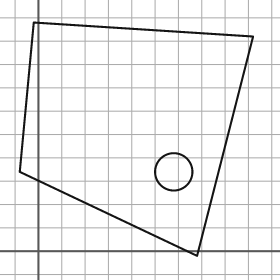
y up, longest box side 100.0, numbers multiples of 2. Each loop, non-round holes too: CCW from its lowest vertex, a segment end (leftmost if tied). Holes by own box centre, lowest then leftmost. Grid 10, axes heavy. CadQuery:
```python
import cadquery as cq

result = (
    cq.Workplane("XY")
    .moveTo(68.0, -2.0)
    .lineTo(92.0, 92.0)
    .lineTo(-2.0, 98.0)
    .lineTo(-8.0, 34.0)
    .close()
    .moveTo(58.0, 34.0)
    .circle(8.0)
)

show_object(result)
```